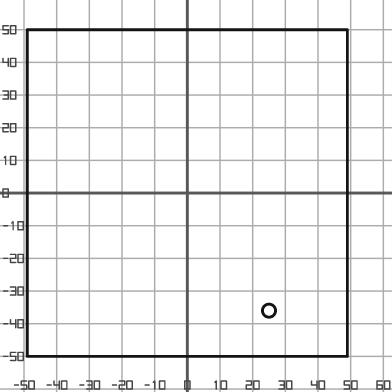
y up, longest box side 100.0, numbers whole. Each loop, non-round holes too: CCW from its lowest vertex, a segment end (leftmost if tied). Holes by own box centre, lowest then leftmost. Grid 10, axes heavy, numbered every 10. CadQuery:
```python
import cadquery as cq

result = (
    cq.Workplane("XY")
    .moveTo(-49.0, -50.0)
    .lineTo(49.0, -50.0)
    .lineTo(49.0, 50.0)
    .lineTo(-49.0, 50.0)
    .close()
    .moveTo(25.0, -36.0)
    .circle(2.0)
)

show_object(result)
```